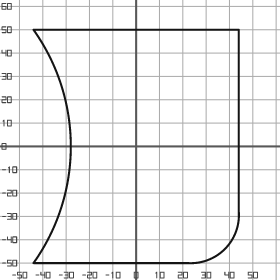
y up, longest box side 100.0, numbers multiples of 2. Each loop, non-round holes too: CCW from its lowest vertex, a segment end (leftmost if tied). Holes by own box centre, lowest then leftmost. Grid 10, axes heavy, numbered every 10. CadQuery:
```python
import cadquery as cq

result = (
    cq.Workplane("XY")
    .moveTo(-44.0, -50.0)
    .lineTo(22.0, -50.0)
    .threePointArc((38.0, -44.0), (44.0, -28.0))
    .lineTo(44.0, 50.0)
    .lineTo(-44.0, 50.0)
    .threePointArc((-28.0, 0.0), (-44.0, -50.0))
    .close()
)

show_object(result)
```